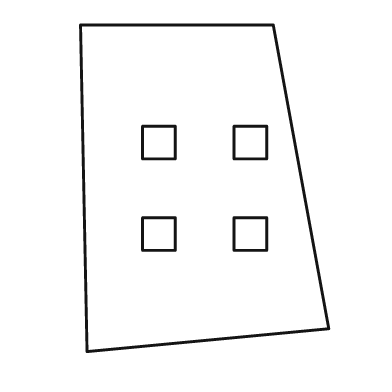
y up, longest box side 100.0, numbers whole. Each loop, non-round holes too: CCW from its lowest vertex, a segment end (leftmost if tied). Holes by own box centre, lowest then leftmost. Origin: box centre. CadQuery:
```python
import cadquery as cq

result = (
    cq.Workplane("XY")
    .moveTo(-36.0, -50.0)
    .lineTo(38.0, -43.0)
    .lineTo(21.0, 50.0)
    .lineTo(-38.0, 50.0)
    .close()
    .moveTo(-19.0, -19.0)
    .lineTo(-9.0, -19.0)
    .lineTo(-9.0, -9.0)
    .lineTo(-19.0, -9.0)
    .close()
    .moveTo(9.0, -19.0)
    .lineTo(19.0, -19.0)
    .lineTo(19.0, -9.0)
    .lineTo(9.0, -9.0)
    .close()
    .moveTo(-19.0, 9.0)
    .lineTo(-9.0, 9.0)
    .lineTo(-9.0, 19.0)
    .lineTo(-19.0, 19.0)
    .close()
    .moveTo(9.0, 9.0)
    .lineTo(19.0, 9.0)
    .lineTo(19.0, 19.0)
    .lineTo(9.0, 19.0)
    .close()
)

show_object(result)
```